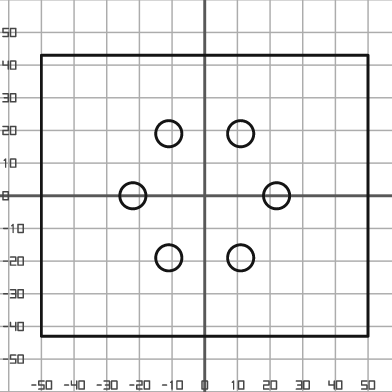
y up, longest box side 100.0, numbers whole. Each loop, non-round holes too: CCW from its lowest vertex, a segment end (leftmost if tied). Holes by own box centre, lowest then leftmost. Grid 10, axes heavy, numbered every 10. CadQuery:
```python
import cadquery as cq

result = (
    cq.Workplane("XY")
    .moveTo(-50.0, -43.0)
    .lineTo(50.0, -43.0)
    .lineTo(50.0, 43.0)
    .lineTo(-50.0, 43.0)
    .close()
    .moveTo(-11.0, -19.0)
    .circle(4.0)
    .moveTo(11.0, -19.0)
    .circle(4.0)
    .moveTo(-22.0, 0.0)
    .circle(4.0)
    .moveTo(22.0, 0.0)
    .circle(4.0)
    .moveTo(-11.0, 19.0)
    .circle(4.0)
    .moveTo(11.0, 19.0)
    .circle(4.0)
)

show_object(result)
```